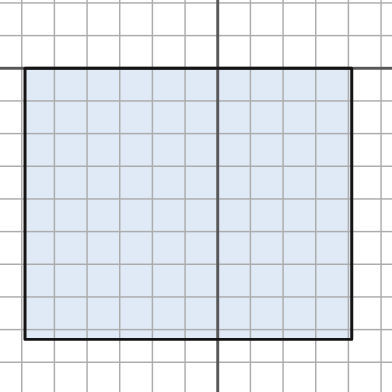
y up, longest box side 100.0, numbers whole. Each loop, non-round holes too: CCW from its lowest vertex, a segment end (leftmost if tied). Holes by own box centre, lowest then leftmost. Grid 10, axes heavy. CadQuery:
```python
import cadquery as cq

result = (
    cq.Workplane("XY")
    .moveTo(-59.0, -83.0)
    .lineTo(41.0, -83.0)
    .lineTo(41.0, 0.0)
    .lineTo(-59.0, 0.0)
    .close()
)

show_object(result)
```